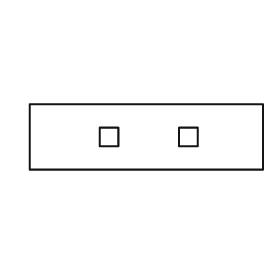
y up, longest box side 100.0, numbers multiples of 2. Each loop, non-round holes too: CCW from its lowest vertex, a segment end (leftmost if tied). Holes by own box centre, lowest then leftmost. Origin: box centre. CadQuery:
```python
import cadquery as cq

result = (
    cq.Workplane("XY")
    .moveTo(-50.0, -14.0)
    .lineTo(50.0, -14.0)
    .lineTo(50.0, 14.0)
    .lineTo(-50.0, 14.0)
    .close()
    .moveTo(-20.0, -4.0)
    .lineTo(-12.0, -4.0)
    .lineTo(-12.0, 4.0)
    .lineTo(-20.0, 4.0)
    .close()
    .moveTo(14.0, -4.0)
    .lineTo(22.0, -4.0)
    .lineTo(22.0, 4.0)
    .lineTo(14.0, 4.0)
    .close()
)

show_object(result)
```